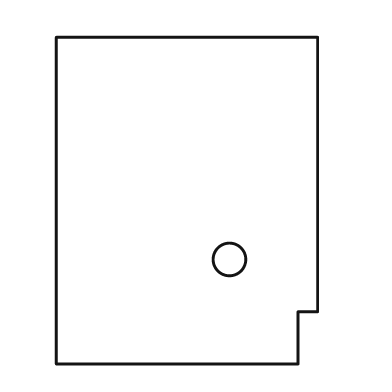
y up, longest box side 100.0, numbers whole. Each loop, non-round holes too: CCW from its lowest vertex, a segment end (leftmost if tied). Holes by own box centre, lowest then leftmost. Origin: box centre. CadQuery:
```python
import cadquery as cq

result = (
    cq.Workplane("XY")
    .moveTo(-40.0, -50.0)
    .lineTo(34.0, -50.0)
    .lineTo(34.0, -34.0)
    .lineTo(40.0, -34.0)
    .lineTo(40.0, 50.0)
    .lineTo(-40.0, 50.0)
    .close()
    .moveTo(13.0, -18.0)
    .circle(5.0)
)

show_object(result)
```